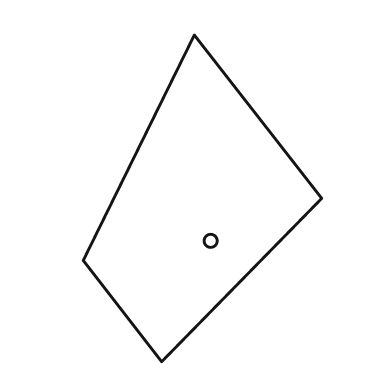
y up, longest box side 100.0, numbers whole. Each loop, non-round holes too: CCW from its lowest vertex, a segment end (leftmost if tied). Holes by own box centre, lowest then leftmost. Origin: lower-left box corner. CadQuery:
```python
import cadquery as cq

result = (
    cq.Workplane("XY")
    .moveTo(24.0, 0.0)
    .lineTo(73.0, 50.0)
    .lineTo(34.0, 100.0)
    .lineTo(0.0, 31.0)
    .close()
    .moveTo(39.0, 37.0)
    .circle(2.0)
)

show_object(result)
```